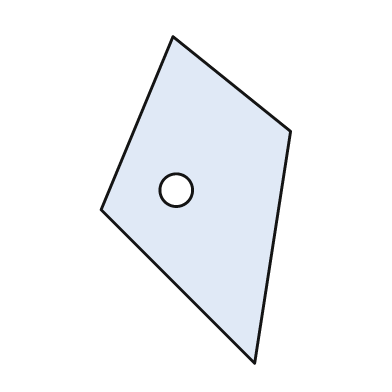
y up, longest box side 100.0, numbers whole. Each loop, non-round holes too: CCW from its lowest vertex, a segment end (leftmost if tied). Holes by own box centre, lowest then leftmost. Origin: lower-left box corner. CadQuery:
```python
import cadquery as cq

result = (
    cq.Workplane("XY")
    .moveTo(47.0, 0.0)
    .lineTo(58.0, 71.0)
    .lineTo(22.0, 100.0)
    .lineTo(0.0, 47.0)
    .close()
    .moveTo(23.0, 53.0)
    .circle(5.0)
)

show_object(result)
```